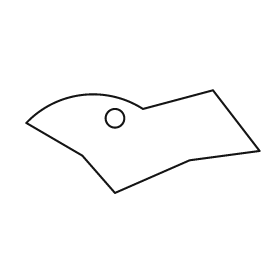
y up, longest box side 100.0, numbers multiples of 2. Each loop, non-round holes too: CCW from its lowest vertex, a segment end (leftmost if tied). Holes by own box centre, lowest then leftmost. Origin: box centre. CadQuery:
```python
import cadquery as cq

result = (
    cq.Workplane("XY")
    .moveTo(-12.0, -22.0)
    .lineTo(20.0, -8.0)
    .lineTo(50.0, -4.0)
    .lineTo(30.0, 22.0)
    .lineTo(0.0, 14.0)
    .threePointArc((-26.0, 20.0), (-50.0, 8.0))
    .lineTo(-26.0, -6.0)
    .close()
    .moveTo(-12.0, 10.0)
    .circle(4.0)
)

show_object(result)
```